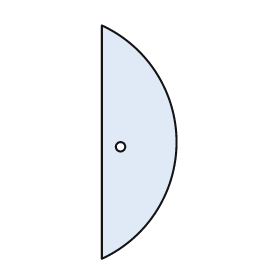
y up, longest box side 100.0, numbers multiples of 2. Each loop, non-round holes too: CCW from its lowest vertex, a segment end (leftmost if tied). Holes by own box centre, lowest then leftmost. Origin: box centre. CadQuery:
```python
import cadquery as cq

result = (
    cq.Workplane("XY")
    .moveTo(-16.0, -50.0)
    .threePointArc((16.0, 0.0), (-16.0, 50.0))
    .close()
    .moveTo(-8.0, -2.0)
    .circle(2.0)
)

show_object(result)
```